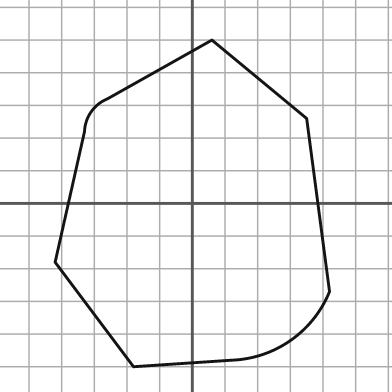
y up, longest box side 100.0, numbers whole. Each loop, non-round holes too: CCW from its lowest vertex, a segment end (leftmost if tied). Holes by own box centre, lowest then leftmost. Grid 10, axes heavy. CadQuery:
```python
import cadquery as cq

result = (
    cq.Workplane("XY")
    .moveTo(-18.0, -50.0)
    .lineTo(12.0, -48.0)
    .threePointArc((30.0, -42.0), (42.0, -27.0))
    .lineTo(35.0, 26.0)
    .lineTo(6.0, 50.0)
    .lineTo(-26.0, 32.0)
    .threePointArc((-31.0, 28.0), (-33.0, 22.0))
    .lineTo(-42.0, -18.0)
    .close()
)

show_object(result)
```